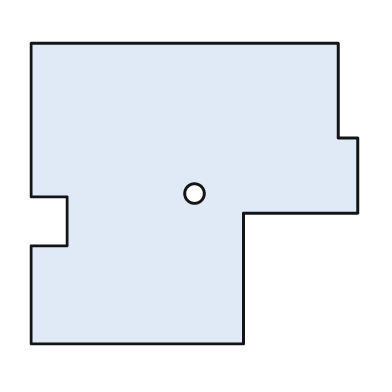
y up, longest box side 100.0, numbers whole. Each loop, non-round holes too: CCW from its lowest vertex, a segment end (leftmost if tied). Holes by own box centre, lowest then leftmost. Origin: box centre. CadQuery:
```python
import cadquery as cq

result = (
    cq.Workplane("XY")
    .moveTo(-50.0, -46.0)
    .lineTo(15.0, -46.0)
    .lineTo(15.0, -6.0)
    .lineTo(50.0, -6.0)
    .lineTo(50.0, 17.0)
    .lineTo(44.0, 17.0)
    .lineTo(44.0, 46.0)
    .lineTo(-50.0, 46.0)
    .lineTo(-50.0, -1.0)
    .lineTo(-39.0, -1.0)
    .lineTo(-39.0, -16.0)
    .lineTo(-50.0, -16.0)
    .close()
    .moveTo(0.0, 0.0)
    .circle(3.0)
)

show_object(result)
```